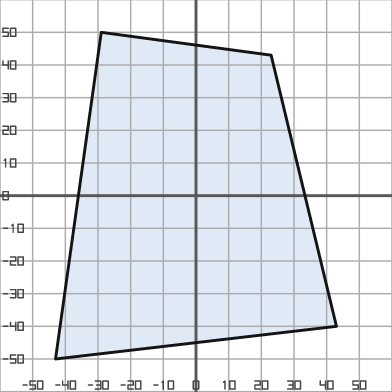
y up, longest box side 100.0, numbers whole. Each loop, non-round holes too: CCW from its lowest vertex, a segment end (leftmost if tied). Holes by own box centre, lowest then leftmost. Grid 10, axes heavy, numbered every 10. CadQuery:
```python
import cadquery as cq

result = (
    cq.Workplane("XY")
    .moveTo(-43.0, -50.0)
    .lineTo(43.0, -40.0)
    .lineTo(23.0, 43.0)
    .lineTo(-29.0, 50.0)
    .close()
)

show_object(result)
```